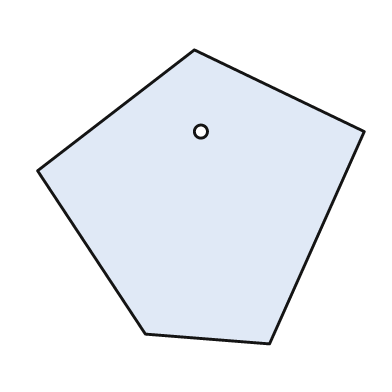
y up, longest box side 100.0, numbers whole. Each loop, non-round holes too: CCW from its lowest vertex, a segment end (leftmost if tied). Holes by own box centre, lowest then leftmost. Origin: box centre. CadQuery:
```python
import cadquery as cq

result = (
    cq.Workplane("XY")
    .moveTo(21.0, -45.0)
    .lineTo(50.0, 20.0)
    .lineTo(-2.0, 45.0)
    .lineTo(-50.0, 8.0)
    .lineTo(-17.0, -42.0)
    .close()
    .moveTo(0.0, 20.0)
    .circle(2.0)
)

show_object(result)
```